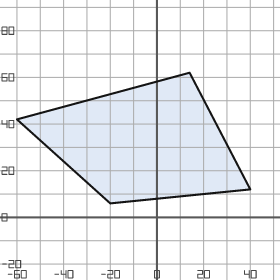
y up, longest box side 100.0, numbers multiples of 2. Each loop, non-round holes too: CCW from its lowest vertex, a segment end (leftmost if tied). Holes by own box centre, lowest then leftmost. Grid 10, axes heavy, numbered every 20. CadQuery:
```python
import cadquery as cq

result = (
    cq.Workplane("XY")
    .moveTo(-20.0, 6.0)
    .lineTo(40.0, 12.0)
    .lineTo(14.0, 62.0)
    .lineTo(-60.0, 42.0)
    .close()
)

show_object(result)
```